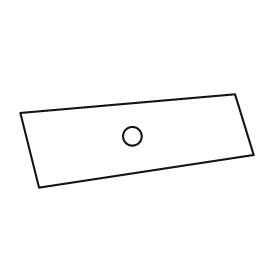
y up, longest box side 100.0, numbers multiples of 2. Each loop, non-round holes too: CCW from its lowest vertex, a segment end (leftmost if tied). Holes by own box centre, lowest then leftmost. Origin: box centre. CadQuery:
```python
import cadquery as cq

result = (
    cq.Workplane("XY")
    .moveTo(-42.0, -20.0)
    .lineTo(50.0, -6.0)
    .lineTo(42.0, 20.0)
    .lineTo(-50.0, 12.0)
    .close()
    .moveTo(-2.0, 2.0)
    .circle(4.0)
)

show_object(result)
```